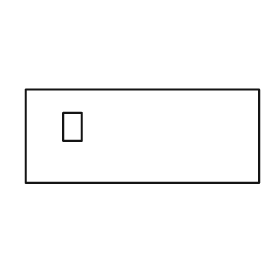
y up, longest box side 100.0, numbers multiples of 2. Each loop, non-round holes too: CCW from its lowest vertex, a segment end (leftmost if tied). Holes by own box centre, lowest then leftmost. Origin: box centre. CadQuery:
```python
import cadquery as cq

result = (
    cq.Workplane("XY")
    .moveTo(-50.0, -20.0)
    .lineTo(50.0, -20.0)
    .lineTo(50.0, 20.0)
    .lineTo(-50.0, 20.0)
    .close()
    .moveTo(-34.0, -2.0)
    .lineTo(-26.0, -2.0)
    .lineTo(-26.0, 10.0)
    .lineTo(-34.0, 10.0)
    .close()
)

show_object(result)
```